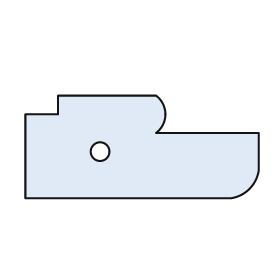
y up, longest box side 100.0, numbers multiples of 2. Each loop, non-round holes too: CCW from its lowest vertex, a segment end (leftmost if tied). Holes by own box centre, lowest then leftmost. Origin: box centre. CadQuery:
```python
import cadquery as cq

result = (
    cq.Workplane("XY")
    .moveTo(-50.0, -22.0)
    .lineTo(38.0, -22.0)
    .threePointArc((46.0, -18.0), (50.0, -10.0))
    .lineTo(50.0, 6.0)
    .lineTo(6.0, 6.0)
    .threePointArc((10.0, 14.0), (6.0, 22.0))
    .lineTo(-36.0, 22.0)
    .lineTo(-36.0, 14.0)
    .lineTo(-50.0, 14.0)
    .close()
    .moveTo(-18.0, -2.0)
    .circle(4.0)
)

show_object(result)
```